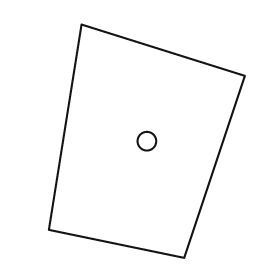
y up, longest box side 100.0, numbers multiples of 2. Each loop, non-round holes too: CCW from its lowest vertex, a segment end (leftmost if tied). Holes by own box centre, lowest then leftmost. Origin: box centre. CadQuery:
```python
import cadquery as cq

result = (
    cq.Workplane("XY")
    .moveTo(16.0, -50.0)
    .lineTo(42.0, 28.0)
    .lineTo(-28.0, 50.0)
    .lineTo(-42.0, -38.0)
    .close()
    .moveTo(0.0, 0.0)
    .circle(4.0)
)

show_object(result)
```